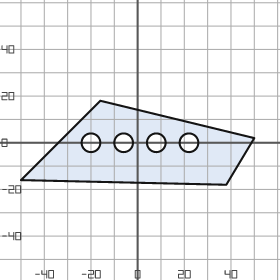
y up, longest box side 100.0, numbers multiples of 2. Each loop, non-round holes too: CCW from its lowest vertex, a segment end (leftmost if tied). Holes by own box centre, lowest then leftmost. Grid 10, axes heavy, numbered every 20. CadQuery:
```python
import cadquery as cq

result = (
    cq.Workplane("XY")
    .moveTo(38.0, -18.0)
    .lineTo(50.0, 2.0)
    .lineTo(-16.0, 18.0)
    .lineTo(-50.0, -16.0)
    .close()
    .moveTo(-20.0, 0.0)
    .circle(4.0)
    .moveTo(-6.0, 0.0)
    .circle(4.0)
    .moveTo(8.0, 0.0)
    .circle(4.0)
    .moveTo(22.0, 0.0)
    .circle(4.0)
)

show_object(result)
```